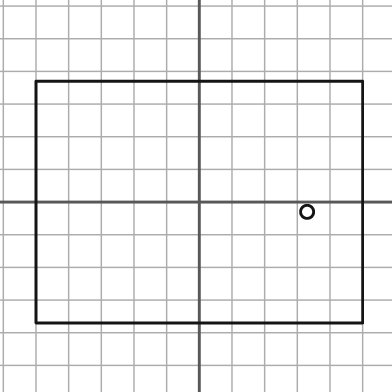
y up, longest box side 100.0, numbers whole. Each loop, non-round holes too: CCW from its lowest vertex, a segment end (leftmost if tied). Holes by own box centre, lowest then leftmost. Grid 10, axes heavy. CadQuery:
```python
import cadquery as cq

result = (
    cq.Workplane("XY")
    .moveTo(-50.0, -37.0)
    .lineTo(50.0, -37.0)
    .lineTo(50.0, 37.0)
    .lineTo(-50.0, 37.0)
    .close()
    .moveTo(33.0, -3.0)
    .circle(2.0)
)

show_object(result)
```